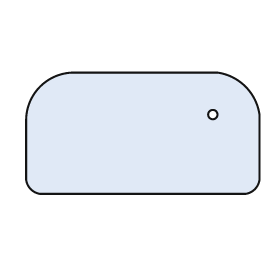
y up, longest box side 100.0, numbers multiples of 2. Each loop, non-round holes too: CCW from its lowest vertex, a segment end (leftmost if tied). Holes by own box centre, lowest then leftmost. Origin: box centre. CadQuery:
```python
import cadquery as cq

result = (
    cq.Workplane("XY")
    .moveTo(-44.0, -26.0)
    .lineTo(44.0, -26.0)
    .threePointArc((48.0, -24.0), (50.0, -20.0))
    .lineTo(50.0, 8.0)
    .threePointArc((44.0, 20.0), (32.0, 26.0))
    .lineTo(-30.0, 26.0)
    .threePointArc((-44.0, 20.0), (-50.0, 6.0))
    .lineTo(-50.0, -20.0)
    .threePointArc((-48.0, -24.0), (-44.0, -26.0))
    .close()
    .moveTo(30.0, 8.0)
    .circle(2.0)
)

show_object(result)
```